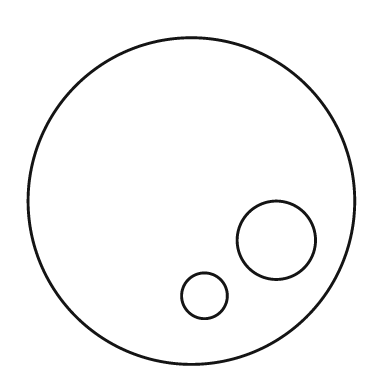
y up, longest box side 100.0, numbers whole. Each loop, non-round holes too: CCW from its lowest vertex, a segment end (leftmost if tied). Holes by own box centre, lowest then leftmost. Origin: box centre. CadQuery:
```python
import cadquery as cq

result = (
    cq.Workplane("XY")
    .moveTo(0.0, 0.0)
    .circle(50.0)
    .moveTo(4.0, -29.0)
    .circle(7.0)
    .moveTo(26.0, -12.0)
    .circle(12.0)
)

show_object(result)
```